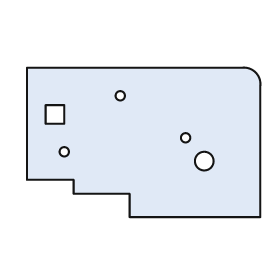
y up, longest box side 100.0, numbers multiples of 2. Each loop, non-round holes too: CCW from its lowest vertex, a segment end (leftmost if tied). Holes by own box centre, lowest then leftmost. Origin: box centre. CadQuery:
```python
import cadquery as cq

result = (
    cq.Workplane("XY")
    .moveTo(-6.0, -32.0)
    .lineTo(50.0, -32.0)
    .lineTo(50.0, 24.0)
    .threePointArc((48.0, 30.0), (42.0, 32.0))
    .lineTo(-50.0, 32.0)
    .lineTo(-50.0, -16.0)
    .lineTo(-30.0, -16.0)
    .lineTo(-30.0, -22.0)
    .lineTo(-6.0, -22.0)
    .close()
    .moveTo(26.0, -8.0)
    .circle(4.0)
    .moveTo(-34.0, -4.0)
    .circle(2.0)
    .moveTo(18.0, 2.0)
    .circle(2.0)
    .moveTo(-42.0, 8.0)
    .lineTo(-34.0, 8.0)
    .lineTo(-34.0, 16.0)
    .lineTo(-42.0, 16.0)
    .close()
    .moveTo(-10.0, 20.0)
    .circle(2.0)
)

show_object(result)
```